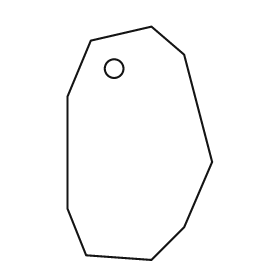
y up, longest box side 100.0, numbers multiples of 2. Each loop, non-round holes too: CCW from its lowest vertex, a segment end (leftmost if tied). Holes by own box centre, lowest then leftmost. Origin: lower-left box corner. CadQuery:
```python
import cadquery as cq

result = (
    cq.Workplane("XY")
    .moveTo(36.0, 0.0)
    .lineTo(50.0, 14.0)
    .lineTo(62.0, 42.0)
    .lineTo(50.0, 88.0)
    .lineTo(36.0, 100.0)
    .lineTo(10.0, 94.0)
    .lineTo(0.0, 70.0)
    .lineTo(0.0, 22.0)
    .lineTo(8.0, 2.0)
    .close()
    .moveTo(20.0, 82.0)
    .circle(4.0)
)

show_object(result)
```